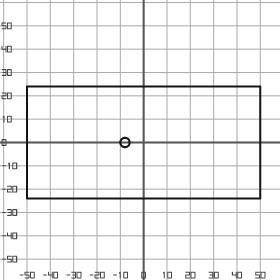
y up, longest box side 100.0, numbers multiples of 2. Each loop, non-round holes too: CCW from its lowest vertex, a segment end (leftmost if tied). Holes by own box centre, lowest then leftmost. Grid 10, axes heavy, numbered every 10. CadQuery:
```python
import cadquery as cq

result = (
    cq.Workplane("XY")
    .moveTo(-50.0, -24.0)
    .lineTo(50.0, -24.0)
    .lineTo(50.0, 24.0)
    .lineTo(-50.0, 24.0)
    .close()
    .moveTo(-8.0, 0.0)
    .circle(2.0)
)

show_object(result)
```